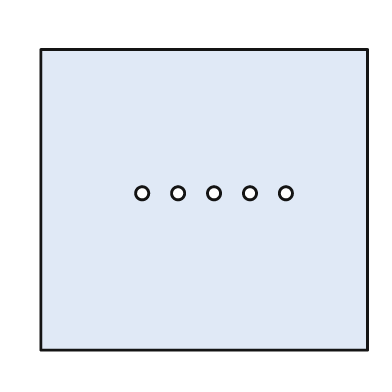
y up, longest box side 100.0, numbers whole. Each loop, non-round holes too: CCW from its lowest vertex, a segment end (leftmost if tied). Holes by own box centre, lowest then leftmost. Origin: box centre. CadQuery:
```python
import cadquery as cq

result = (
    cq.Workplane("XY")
    .moveTo(-50.0, -46.0)
    .lineTo(50.0, -46.0)
    .lineTo(50.0, 46.0)
    .lineTo(-50.0, 46.0)
    .close()
    .moveTo(-19.0, 2.0)
    .circle(2.0)
    .moveTo(-8.0, 2.0)
    .circle(2.0)
    .moveTo(3.0, 2.0)
    .circle(2.0)
    .moveTo(14.0, 2.0)
    .circle(2.0)
    .moveTo(25.0, 2.0)
    .circle(2.0)
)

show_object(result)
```